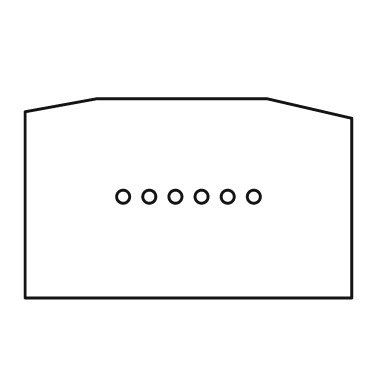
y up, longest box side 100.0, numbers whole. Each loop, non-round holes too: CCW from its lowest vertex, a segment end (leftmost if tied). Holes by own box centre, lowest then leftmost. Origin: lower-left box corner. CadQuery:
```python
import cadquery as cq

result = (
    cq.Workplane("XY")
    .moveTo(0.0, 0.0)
    .lineTo(100.0, 0.0)
    .lineTo(100.0, 55.0)
    .lineTo(74.0, 61.0)
    .lineTo(22.0, 61.0)
    .lineTo(0.0, 57.0)
    .close()
    .moveTo(30.0, 31.0)
    .circle(2.0)
    .moveTo(38.0, 31.0)
    .circle(2.0)
    .moveTo(46.0, 31.0)
    .circle(2.0)
    .moveTo(54.0, 31.0)
    .circle(2.0)
    .moveTo(62.0, 31.0)
    .circle(2.0)
    .moveTo(70.0, 31.0)
    .circle(2.0)
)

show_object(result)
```